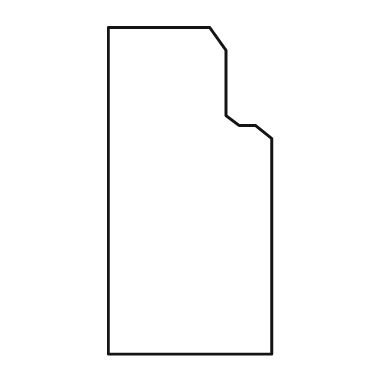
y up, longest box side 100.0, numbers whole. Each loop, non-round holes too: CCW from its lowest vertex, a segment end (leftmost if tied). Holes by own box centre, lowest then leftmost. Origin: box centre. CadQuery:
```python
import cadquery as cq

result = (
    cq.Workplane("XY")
    .moveTo(-25.0, -50.0)
    .lineTo(25.0, -50.0)
    .lineTo(25.0, 16.0)
    .lineTo(20.0, 20.0)
    .lineTo(15.0, 20.0)
    .lineTo(11.0, 23.0)
    .lineTo(11.0, 43.0)
    .lineTo(6.0, 50.0)
    .lineTo(-25.0, 50.0)
    .close()
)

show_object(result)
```